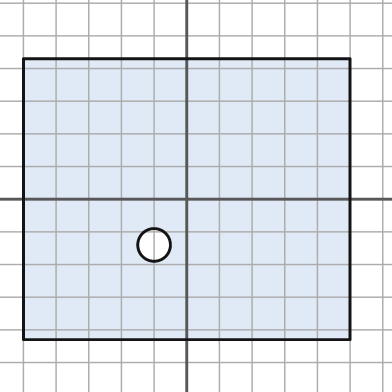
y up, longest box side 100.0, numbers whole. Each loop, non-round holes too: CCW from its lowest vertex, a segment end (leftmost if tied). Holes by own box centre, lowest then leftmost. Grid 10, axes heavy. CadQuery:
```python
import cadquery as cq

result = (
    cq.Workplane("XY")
    .moveTo(-50.0, -43.0)
    .lineTo(50.0, -43.0)
    .lineTo(50.0, 43.0)
    .lineTo(-50.0, 43.0)
    .close()
    .moveTo(-10.0, -14.0)
    .circle(5.0)
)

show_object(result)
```